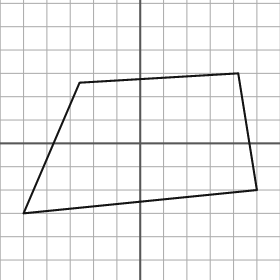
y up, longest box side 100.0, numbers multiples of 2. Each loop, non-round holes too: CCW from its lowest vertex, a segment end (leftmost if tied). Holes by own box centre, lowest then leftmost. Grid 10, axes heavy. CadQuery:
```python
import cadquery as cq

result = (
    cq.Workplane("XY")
    .moveTo(-50.0, -30.0)
    .lineTo(50.0, -20.0)
    .lineTo(42.0, 30.0)
    .lineTo(-26.0, 26.0)
    .close()
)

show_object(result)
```